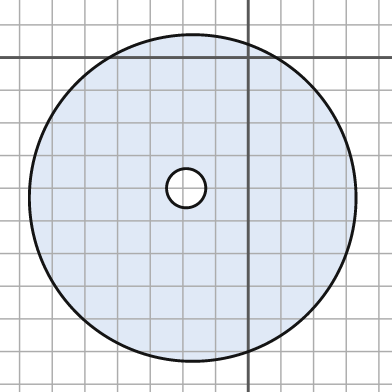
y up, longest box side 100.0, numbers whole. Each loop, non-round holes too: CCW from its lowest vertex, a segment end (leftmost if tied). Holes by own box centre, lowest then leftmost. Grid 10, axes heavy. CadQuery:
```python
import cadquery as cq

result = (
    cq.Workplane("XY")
    .moveTo(-17.0, -43.0)
    .circle(50.0)
    .moveTo(-19.0, -40.0)
    .circle(6.0)
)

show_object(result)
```